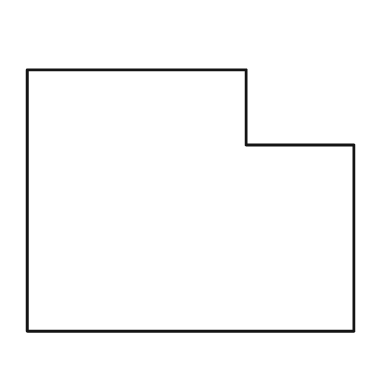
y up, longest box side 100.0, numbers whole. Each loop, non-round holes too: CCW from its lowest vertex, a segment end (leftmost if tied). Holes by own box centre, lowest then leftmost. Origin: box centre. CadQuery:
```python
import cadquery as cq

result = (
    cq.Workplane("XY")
    .moveTo(-50.0, -40.0)
    .lineTo(50.0, -40.0)
    .lineTo(50.0, 17.0)
    .lineTo(17.0, 17.0)
    .lineTo(17.0, 40.0)
    .lineTo(-50.0, 40.0)
    .close()
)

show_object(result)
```